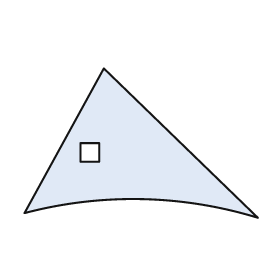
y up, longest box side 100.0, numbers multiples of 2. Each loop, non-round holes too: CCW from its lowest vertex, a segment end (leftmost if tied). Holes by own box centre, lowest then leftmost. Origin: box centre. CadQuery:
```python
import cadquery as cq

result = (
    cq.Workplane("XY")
    .moveTo(50.0, -32.0)
    .lineTo(-16.0, 32.0)
    .lineTo(-50.0, -30.0)
    .threePointArc((0.0, -24.0), (50.0, -32.0))
    .close()
    .moveTo(-26.0, -8.0)
    .lineTo(-18.0, -8.0)
    .lineTo(-18.0, 0.0)
    .lineTo(-26.0, 0.0)
    .close()
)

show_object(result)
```